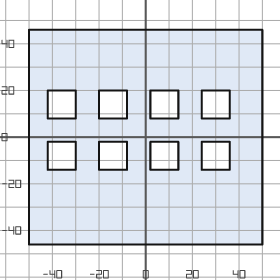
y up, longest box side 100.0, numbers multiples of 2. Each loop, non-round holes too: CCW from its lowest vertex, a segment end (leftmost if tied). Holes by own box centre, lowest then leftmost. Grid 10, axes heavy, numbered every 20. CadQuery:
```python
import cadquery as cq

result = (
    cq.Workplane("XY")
    .moveTo(-50.0, -46.0)
    .lineTo(50.0, -46.0)
    .lineTo(50.0, 46.0)
    .lineTo(-50.0, 46.0)
    .close()
    .moveTo(-42.0, -14.0)
    .lineTo(-30.0, -14.0)
    .lineTo(-30.0, -2.0)
    .lineTo(-42.0, -2.0)
    .close()
    .moveTo(-20.0, -14.0)
    .lineTo(-8.0, -14.0)
    .lineTo(-8.0, -2.0)
    .lineTo(-20.0, -2.0)
    .close()
    .moveTo(2.0, -14.0)
    .lineTo(14.0, -14.0)
    .lineTo(14.0, -2.0)
    .lineTo(2.0, -2.0)
    .close()
    .moveTo(24.0, -14.0)
    .lineTo(36.0, -14.0)
    .lineTo(36.0, -2.0)
    .lineTo(24.0, -2.0)
    .close()
    .moveTo(-42.0, 8.0)
    .lineTo(-30.0, 8.0)
    .lineTo(-30.0, 20.0)
    .lineTo(-42.0, 20.0)
    .close()
    .moveTo(-20.0, 8.0)
    .lineTo(-8.0, 8.0)
    .lineTo(-8.0, 20.0)
    .lineTo(-20.0, 20.0)
    .close()
    .moveTo(2.0, 8.0)
    .lineTo(14.0, 8.0)
    .lineTo(14.0, 20.0)
    .lineTo(2.0, 20.0)
    .close()
    .moveTo(24.0, 8.0)
    .lineTo(36.0, 8.0)
    .lineTo(36.0, 20.0)
    .lineTo(24.0, 20.0)
    .close()
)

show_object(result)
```